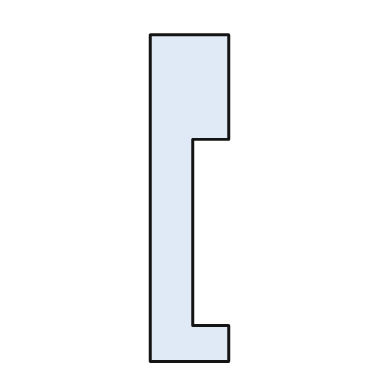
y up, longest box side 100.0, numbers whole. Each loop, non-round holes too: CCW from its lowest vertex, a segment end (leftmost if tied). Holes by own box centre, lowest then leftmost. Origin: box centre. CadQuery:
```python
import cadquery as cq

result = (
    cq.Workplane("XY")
    .moveTo(-12.0, -50.0)
    .lineTo(12.0, -50.0)
    .lineTo(12.0, -39.0)
    .lineTo(1.0, -39.0)
    .lineTo(1.0, 18.0)
    .lineTo(12.0, 18.0)
    .lineTo(12.0, 50.0)
    .lineTo(-12.0, 50.0)
    .close()
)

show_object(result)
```